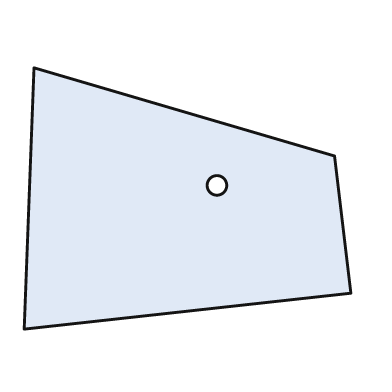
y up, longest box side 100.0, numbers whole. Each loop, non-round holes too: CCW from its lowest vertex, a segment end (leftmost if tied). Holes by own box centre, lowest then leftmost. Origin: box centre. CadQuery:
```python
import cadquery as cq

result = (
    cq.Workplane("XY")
    .moveTo(-50.0, -40.0)
    .lineTo(50.0, -29.0)
    .lineTo(45.0, 13.0)
    .lineTo(-47.0, 40.0)
    .close()
    .moveTo(9.0, 4.0)
    .circle(3.0)
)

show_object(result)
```